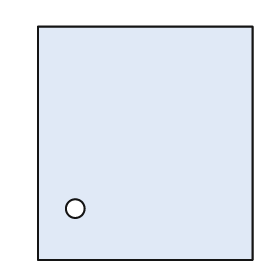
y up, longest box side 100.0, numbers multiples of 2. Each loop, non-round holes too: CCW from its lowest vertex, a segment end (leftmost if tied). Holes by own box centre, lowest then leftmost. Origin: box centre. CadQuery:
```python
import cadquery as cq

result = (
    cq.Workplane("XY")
    .moveTo(-46.0, -50.0)
    .lineTo(46.0, -50.0)
    .lineTo(46.0, 50.0)
    .lineTo(-46.0, 50.0)
    .close()
    .moveTo(-30.0, -28.0)
    .circle(4.0)
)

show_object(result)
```